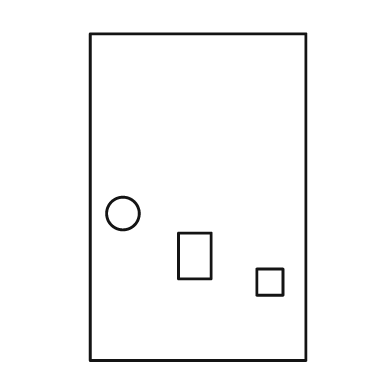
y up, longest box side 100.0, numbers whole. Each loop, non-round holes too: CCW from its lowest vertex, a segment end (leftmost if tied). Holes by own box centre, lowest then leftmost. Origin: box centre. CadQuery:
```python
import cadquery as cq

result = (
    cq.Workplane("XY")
    .moveTo(-33.0, -50.0)
    .lineTo(33.0, -50.0)
    .lineTo(33.0, 50.0)
    .lineTo(-33.0, 50.0)
    .close()
    .moveTo(18.0, -30.0)
    .lineTo(26.0, -30.0)
    .lineTo(26.0, -22.0)
    .lineTo(18.0, -22.0)
    .close()
    .moveTo(-6.0, -25.0)
    .lineTo(4.0, -25.0)
    .lineTo(4.0, -11.0)
    .lineTo(-6.0, -11.0)
    .close()
    .moveTo(-23.0, -5.0)
    .circle(5.0)
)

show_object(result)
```